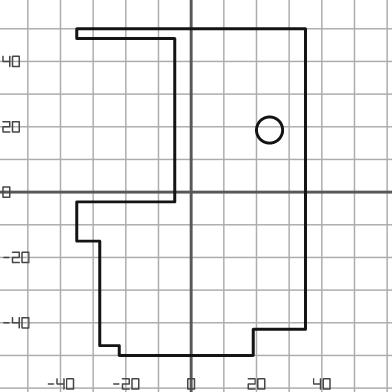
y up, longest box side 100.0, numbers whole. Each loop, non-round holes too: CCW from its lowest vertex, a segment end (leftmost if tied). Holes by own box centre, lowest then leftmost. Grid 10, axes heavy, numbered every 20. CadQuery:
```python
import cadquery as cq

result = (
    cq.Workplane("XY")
    .moveTo(-22.0, -50.0)
    .lineTo(19.0, -50.0)
    .lineTo(19.0, -42.0)
    .lineTo(35.0, -42.0)
    .lineTo(35.0, 50.0)
    .lineTo(-35.0, 50.0)
    .lineTo(-35.0, 47.0)
    .lineTo(-5.0, 47.0)
    .lineTo(-5.0, -3.0)
    .lineTo(-35.0, -3.0)
    .lineTo(-35.0, -15.0)
    .lineTo(-28.0, -15.0)
    .lineTo(-28.0, -47.0)
    .lineTo(-22.0, -47.0)
    .close()
    .moveTo(24.0, 19.0)
    .circle(4.0)
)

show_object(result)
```